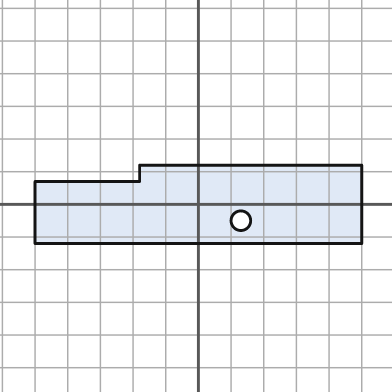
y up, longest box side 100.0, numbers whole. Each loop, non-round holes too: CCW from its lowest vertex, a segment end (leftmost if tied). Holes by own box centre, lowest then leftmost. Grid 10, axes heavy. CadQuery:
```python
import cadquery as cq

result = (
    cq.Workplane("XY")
    .moveTo(-50.0, -12.0)
    .lineTo(50.0, -12.0)
    .lineTo(50.0, 12.0)
    .lineTo(-18.0, 12.0)
    .lineTo(-18.0, 7.0)
    .lineTo(-50.0, 7.0)
    .close()
    .moveTo(13.0, -5.0)
    .circle(3.0)
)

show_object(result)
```